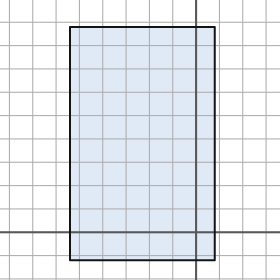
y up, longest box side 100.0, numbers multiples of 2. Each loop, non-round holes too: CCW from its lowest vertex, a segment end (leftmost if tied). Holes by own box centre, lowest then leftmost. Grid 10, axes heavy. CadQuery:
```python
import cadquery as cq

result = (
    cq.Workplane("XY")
    .moveTo(-54.0, -12.0)
    .lineTo(8.0, -12.0)
    .lineTo(8.0, 88.0)
    .lineTo(-54.0, 88.0)
    .close()
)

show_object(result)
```